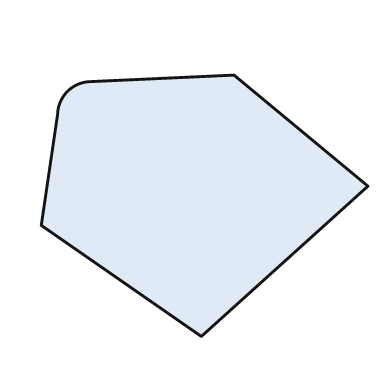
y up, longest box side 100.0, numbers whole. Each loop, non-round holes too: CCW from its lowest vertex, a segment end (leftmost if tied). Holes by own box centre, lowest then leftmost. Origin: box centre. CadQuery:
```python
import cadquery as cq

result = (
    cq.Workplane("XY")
    .moveTo(-1.0, -40.0)
    .lineTo(50.0, 6.0)
    .lineTo(9.0, 40.0)
    .lineTo(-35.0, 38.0)
    .threePointArc((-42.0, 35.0), (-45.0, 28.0))
    .lineTo(-50.0, -6.0)
    .close()
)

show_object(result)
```